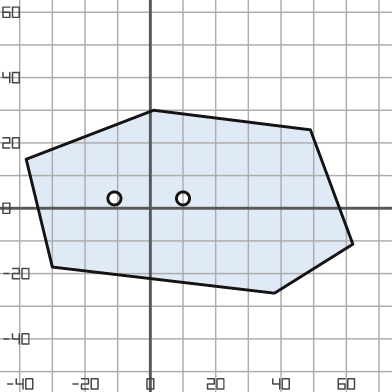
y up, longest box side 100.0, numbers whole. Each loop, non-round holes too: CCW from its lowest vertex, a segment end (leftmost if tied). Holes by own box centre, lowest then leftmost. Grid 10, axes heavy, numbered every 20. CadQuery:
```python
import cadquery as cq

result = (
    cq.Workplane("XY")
    .moveTo(38.0, -26.0)
    .lineTo(62.0, -11.0)
    .lineTo(49.0, 24.0)
    .lineTo(1.0, 30.0)
    .lineTo(-38.0, 15.0)
    .lineTo(-30.0, -18.0)
    .close()
    .moveTo(-11.0, 3.0)
    .circle(2.0)
    .moveTo(10.0, 3.0)
    .circle(2.0)
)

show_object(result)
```